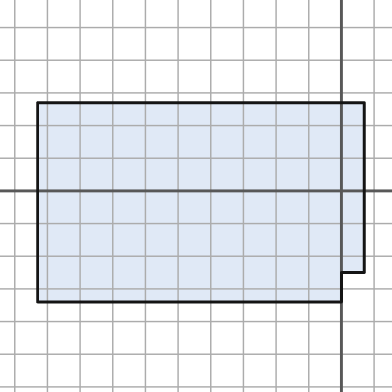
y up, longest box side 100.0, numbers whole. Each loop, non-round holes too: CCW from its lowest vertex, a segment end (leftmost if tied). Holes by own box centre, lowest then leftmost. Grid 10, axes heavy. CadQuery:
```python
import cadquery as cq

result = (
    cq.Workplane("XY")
    .moveTo(-93.0, -34.0)
    .lineTo(0.0, -34.0)
    .lineTo(0.0, -25.0)
    .lineTo(7.0, -25.0)
    .lineTo(7.0, 27.0)
    .lineTo(-93.0, 27.0)
    .close()
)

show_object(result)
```